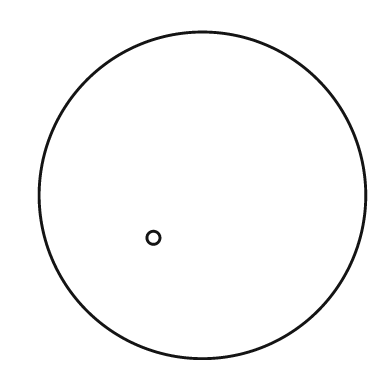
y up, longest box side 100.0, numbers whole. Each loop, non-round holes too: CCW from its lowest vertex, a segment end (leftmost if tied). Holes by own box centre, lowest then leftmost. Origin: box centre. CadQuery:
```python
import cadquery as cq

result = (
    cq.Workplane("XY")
    .moveTo(0.0, 0.0)
    .circle(50.0)
    .moveTo(-15.0, -13.0)
    .circle(2.0)
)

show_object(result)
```